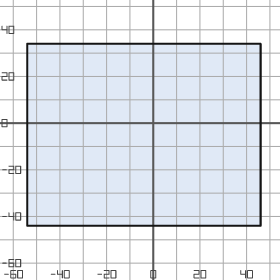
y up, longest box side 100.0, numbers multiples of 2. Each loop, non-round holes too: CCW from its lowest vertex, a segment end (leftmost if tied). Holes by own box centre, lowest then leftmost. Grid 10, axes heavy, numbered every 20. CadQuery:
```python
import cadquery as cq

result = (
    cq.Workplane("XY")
    .moveTo(-54.0, -44.0)
    .lineTo(46.0, -44.0)
    .lineTo(46.0, 34.0)
    .lineTo(-54.0, 34.0)
    .close()
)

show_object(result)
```